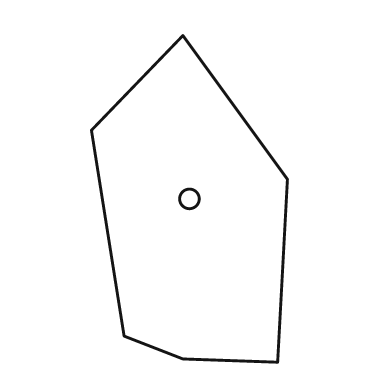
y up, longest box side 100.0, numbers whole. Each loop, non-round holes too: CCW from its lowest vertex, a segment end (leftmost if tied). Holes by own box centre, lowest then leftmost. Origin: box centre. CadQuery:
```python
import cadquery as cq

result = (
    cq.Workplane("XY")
    .moveTo(27.0, -50.0)
    .lineTo(30.0, 6.0)
    .lineTo(-2.0, 50.0)
    .lineTo(-30.0, 21.0)
    .lineTo(-20.0, -42.0)
    .lineTo(-2.0, -49.0)
    .close()
    .moveTo(0.0, 0.0)
    .circle(3.0)
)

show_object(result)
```